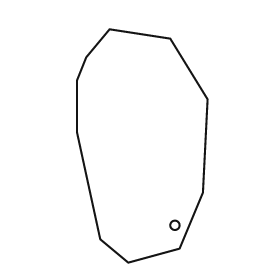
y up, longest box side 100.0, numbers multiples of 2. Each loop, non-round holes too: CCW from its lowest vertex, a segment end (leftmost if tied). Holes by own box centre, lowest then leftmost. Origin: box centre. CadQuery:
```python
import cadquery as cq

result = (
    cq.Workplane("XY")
    .moveTo(-6.0, -50.0)
    .lineTo(16.0, -44.0)
    .lineTo(26.0, -20.0)
    .lineTo(28.0, 20.0)
    .lineTo(12.0, 46.0)
    .lineTo(-14.0, 50.0)
    .lineTo(-24.0, 38.0)
    .lineTo(-28.0, 28.0)
    .lineTo(-28.0, 6.0)
    .lineTo(-18.0, -40.0)
    .close()
    .moveTo(14.0, -34.0)
    .circle(2.0)
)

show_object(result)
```